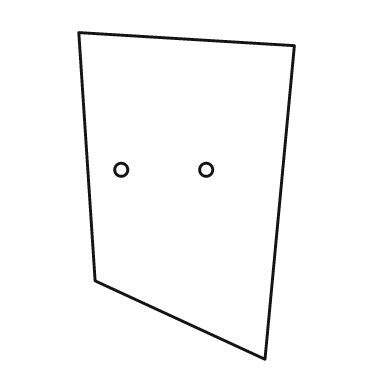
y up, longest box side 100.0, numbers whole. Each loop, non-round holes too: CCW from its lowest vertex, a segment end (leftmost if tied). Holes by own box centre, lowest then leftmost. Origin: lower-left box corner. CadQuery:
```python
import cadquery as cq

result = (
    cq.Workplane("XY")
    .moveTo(57.0, 0.0)
    .lineTo(66.0, 96.0)
    .lineTo(0.0, 100.0)
    .lineTo(5.0, 24.0)
    .close()
    .moveTo(13.0, 58.0)
    .circle(2.0)
    .moveTo(39.0, 58.0)
    .circle(2.0)
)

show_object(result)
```